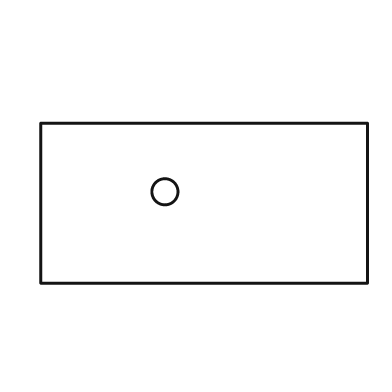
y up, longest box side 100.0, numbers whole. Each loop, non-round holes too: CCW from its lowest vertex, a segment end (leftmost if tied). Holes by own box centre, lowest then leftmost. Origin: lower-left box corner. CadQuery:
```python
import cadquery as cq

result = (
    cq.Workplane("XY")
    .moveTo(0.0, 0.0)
    .lineTo(100.0, 0.0)
    .lineTo(100.0, 49.0)
    .lineTo(0.0, 49.0)
    .close()
    .moveTo(38.0, 28.0)
    .circle(4.0)
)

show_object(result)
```